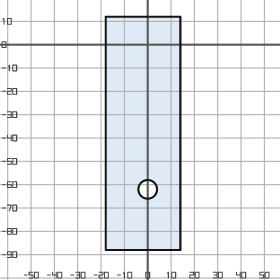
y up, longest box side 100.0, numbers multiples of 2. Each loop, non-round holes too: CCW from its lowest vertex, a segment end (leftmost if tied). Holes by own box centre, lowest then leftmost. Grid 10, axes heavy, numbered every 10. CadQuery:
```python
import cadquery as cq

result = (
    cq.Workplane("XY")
    .moveTo(-18.0, -88.0)
    .lineTo(14.0, -88.0)
    .lineTo(14.0, 12.0)
    .lineTo(-18.0, 12.0)
    .close()
    .moveTo(0.0, -62.0)
    .circle(4.0)
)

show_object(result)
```